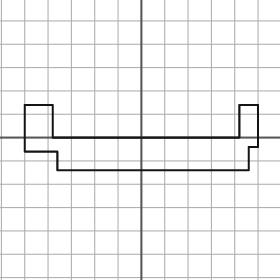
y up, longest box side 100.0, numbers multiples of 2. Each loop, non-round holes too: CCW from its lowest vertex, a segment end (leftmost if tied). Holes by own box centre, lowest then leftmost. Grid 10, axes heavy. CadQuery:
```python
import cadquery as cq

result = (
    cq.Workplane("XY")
    .moveTo(-36.0, -14.0)
    .lineTo(46.0, -14.0)
    .lineTo(46.0, -4.0)
    .lineTo(50.0, -4.0)
    .lineTo(50.0, 14.0)
    .lineTo(42.0, 14.0)
    .lineTo(42.0, 0.0)
    .lineTo(-38.0, 0.0)
    .lineTo(-38.0, 14.0)
    .lineTo(-50.0, 14.0)
    .lineTo(-50.0, -6.0)
    .lineTo(-36.0, -6.0)
    .close()
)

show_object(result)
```